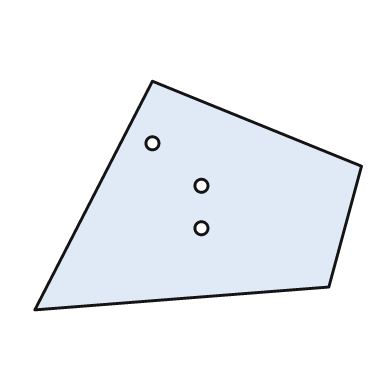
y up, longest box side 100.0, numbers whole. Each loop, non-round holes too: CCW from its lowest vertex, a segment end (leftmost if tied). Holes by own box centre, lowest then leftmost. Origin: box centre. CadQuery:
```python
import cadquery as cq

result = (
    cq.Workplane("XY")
    .moveTo(-50.0, -35.0)
    .lineTo(40.0, -28.0)
    .lineTo(50.0, 9.0)
    .lineTo(-14.0, 35.0)
    .close()
    .moveTo(1.0, -10.0)
    .circle(2.0)
    .moveTo(1.0, 3.0)
    .circle(2.0)
    .moveTo(-14.0, 16.0)
    .circle(2.0)
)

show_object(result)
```